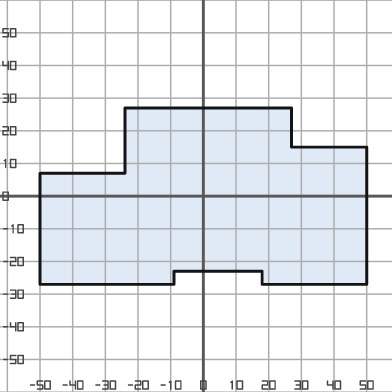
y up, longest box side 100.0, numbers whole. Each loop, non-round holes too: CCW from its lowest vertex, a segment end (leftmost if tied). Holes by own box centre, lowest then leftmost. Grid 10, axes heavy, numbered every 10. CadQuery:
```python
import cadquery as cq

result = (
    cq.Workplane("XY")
    .moveTo(-50.0, -27.0)
    .lineTo(-9.0, -27.0)
    .lineTo(-9.0, -23.0)
    .lineTo(18.0, -23.0)
    .lineTo(18.0, -27.0)
    .lineTo(50.0, -27.0)
    .lineTo(50.0, 15.0)
    .lineTo(27.0, 15.0)
    .lineTo(27.0, 27.0)
    .lineTo(-24.0, 27.0)
    .lineTo(-24.0, 7.0)
    .lineTo(-50.0, 7.0)
    .close()
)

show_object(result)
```